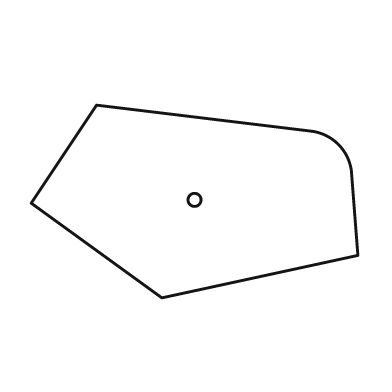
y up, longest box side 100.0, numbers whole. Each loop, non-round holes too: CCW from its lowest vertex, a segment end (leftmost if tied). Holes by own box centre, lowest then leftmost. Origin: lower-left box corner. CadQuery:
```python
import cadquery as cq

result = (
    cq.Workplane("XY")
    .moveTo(40.0, 0.0)
    .lineTo(100.0, 13.0)
    .lineTo(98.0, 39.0)
    .threePointArc((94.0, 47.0), (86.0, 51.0))
    .lineTo(20.0, 59.0)
    .lineTo(0.0, 29.0)
    .close()
    .moveTo(50.0, 30.0)
    .circle(2.0)
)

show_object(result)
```